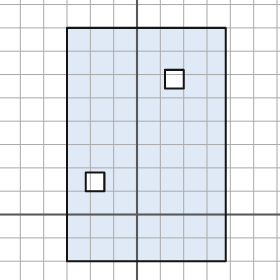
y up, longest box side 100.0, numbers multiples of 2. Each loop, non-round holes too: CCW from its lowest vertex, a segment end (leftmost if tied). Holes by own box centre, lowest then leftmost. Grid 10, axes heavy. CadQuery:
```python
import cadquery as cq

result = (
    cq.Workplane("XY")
    .moveTo(-30.0, -20.0)
    .lineTo(38.0, -20.0)
    .lineTo(38.0, 80.0)
    .lineTo(-30.0, 80.0)
    .close()
    .moveTo(-22.0, 10.0)
    .lineTo(-14.0, 10.0)
    .lineTo(-14.0, 18.0)
    .lineTo(-22.0, 18.0)
    .close()
    .moveTo(12.0, 54.0)
    .lineTo(20.0, 54.0)
    .lineTo(20.0, 62.0)
    .lineTo(12.0, 62.0)
    .close()
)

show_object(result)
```